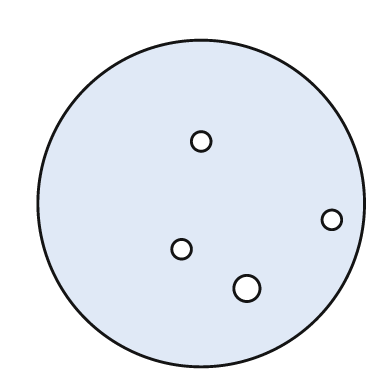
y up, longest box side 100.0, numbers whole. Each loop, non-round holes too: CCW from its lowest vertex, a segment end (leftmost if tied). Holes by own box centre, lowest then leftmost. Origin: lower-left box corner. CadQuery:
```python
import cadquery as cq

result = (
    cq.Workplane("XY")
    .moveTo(50.0, 50.0)
    .circle(50.0)
    .moveTo(64.0, 24.0)
    .circle(4.0)
    .moveTo(44.0, 36.0)
    .circle(3.0)
    .moveTo(90.0, 45.0)
    .circle(3.0)
    .moveTo(50.0, 69.0)
    .circle(3.0)
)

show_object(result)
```